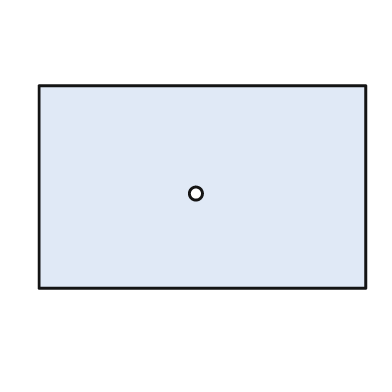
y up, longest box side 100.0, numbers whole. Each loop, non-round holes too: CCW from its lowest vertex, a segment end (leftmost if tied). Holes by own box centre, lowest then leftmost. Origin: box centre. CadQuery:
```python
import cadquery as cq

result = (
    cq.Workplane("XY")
    .moveTo(-50.0, -31.0)
    .lineTo(50.0, -31.0)
    .lineTo(50.0, 31.0)
    .lineTo(-50.0, 31.0)
    .close()
    .moveTo(-2.0, -2.0)
    .circle(2.0)
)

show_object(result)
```